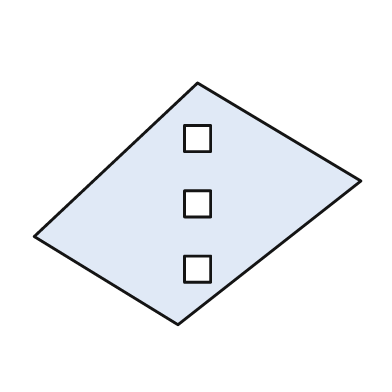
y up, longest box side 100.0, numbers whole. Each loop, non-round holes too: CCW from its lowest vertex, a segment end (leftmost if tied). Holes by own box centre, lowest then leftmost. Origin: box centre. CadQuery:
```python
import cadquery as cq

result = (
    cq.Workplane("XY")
    .moveTo(-6.0, -37.0)
    .lineTo(50.0, 7.0)
    .lineTo(0.0, 37.0)
    .lineTo(-50.0, -10.0)
    .close()
    .moveTo(-4.0, -24.0)
    .lineTo(4.0, -24.0)
    .lineTo(4.0, -16.0)
    .lineTo(-4.0, -16.0)
    .close()
    .moveTo(-4.0, -4.0)
    .lineTo(4.0, -4.0)
    .lineTo(4.0, 4.0)
    .lineTo(-4.0, 4.0)
    .close()
    .moveTo(-4.0, 16.0)
    .lineTo(4.0, 16.0)
    .lineTo(4.0, 24.0)
    .lineTo(-4.0, 24.0)
    .close()
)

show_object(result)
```